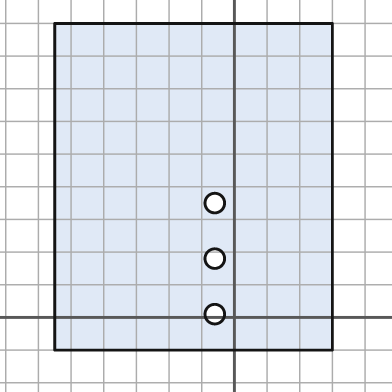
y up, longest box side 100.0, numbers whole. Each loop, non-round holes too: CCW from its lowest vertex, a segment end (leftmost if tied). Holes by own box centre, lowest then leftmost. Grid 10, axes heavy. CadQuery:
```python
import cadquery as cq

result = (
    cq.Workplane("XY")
    .moveTo(-55.0, -10.0)
    .lineTo(30.0, -10.0)
    .lineTo(30.0, 90.0)
    .lineTo(-55.0, 90.0)
    .close()
    .moveTo(-6.0, 1.0)
    .circle(3.0)
    .moveTo(-6.0, 18.0)
    .circle(3.0)
    .moveTo(-6.0, 35.0)
    .circle(3.0)
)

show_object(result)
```